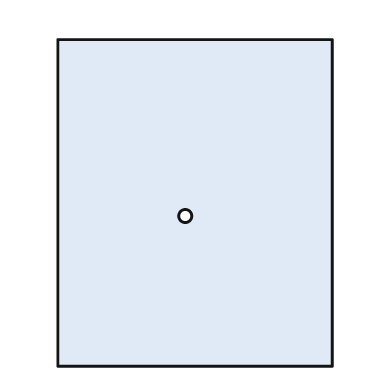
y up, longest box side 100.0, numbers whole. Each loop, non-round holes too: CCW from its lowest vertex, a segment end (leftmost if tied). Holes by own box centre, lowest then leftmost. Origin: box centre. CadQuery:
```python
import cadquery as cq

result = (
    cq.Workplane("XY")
    .moveTo(-42.0, -50.0)
    .lineTo(42.0, -50.0)
    .lineTo(42.0, 50.0)
    .lineTo(-42.0, 50.0)
    .close()
    .moveTo(-3.0, -4.0)
    .circle(2.0)
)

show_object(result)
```